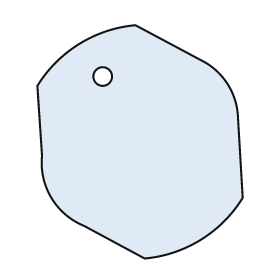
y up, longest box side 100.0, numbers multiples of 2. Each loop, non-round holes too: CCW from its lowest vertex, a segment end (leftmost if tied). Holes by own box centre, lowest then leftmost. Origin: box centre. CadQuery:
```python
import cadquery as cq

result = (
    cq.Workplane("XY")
    .moveTo(2.0, -50.0)
    .threePointArc((26.0, -42.0), (44.0, -24.0))
    .lineTo(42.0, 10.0)
    .threePointArc((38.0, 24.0), (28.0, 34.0))
    .lineTo(-2.0, 50.0)
    .threePointArc((-26.0, 42.0), (-44.0, 24.0))
    .lineTo(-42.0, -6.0)
    .threePointArc((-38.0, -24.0), (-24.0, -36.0))
    .close()
    .moveTo(-16.0, 28.0)
    .circle(4.0)
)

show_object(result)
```